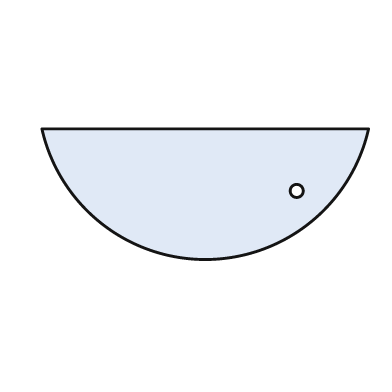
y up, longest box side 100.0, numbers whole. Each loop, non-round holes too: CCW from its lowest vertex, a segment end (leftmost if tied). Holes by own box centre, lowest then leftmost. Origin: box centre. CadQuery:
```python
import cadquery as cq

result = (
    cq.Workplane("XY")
    .moveTo(-50.0, 20.0)
    .threePointArc((0.0, -20.0), (50.0, 20.0))
    .close()
    .moveTo(28.0, 1.0)
    .circle(2.0)
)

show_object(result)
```